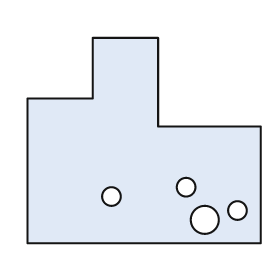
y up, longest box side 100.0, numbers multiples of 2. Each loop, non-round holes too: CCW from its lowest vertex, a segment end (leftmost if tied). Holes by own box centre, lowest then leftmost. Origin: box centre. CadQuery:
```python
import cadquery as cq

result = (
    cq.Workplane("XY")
    .moveTo(-50.0, -44.0)
    .lineTo(50.0, -44.0)
    .lineTo(50.0, 6.0)
    .lineTo(6.0, 6.0)
    .lineTo(6.0, 44.0)
    .lineTo(-22.0, 44.0)
    .lineTo(-22.0, 18.0)
    .lineTo(-50.0, 18.0)
    .close()
    .moveTo(26.0, -34.0)
    .circle(6.0)
    .moveTo(40.0, -30.0)
    .circle(4.0)
    .moveTo(-14.0, -24.0)
    .circle(4.0)
    .moveTo(18.0, -20.0)
    .circle(4.0)
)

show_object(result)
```